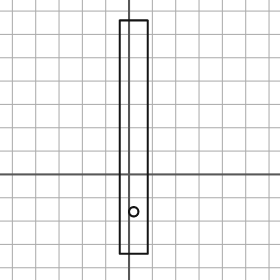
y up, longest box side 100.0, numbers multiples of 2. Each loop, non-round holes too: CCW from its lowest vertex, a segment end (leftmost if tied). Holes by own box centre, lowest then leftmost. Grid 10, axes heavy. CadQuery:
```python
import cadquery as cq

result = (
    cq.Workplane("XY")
    .moveTo(-4.0, -34.0)
    .lineTo(8.0, -34.0)
    .lineTo(8.0, 66.0)
    .lineTo(-4.0, 66.0)
    .close()
    .moveTo(2.0, -16.0)
    .circle(2.0)
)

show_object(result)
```